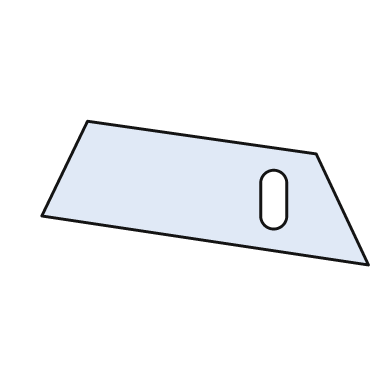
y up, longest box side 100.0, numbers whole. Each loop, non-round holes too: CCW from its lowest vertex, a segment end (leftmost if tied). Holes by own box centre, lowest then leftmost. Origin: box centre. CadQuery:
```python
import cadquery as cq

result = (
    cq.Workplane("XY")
    .moveTo(50.0, -22.0)
    .lineTo(34.0, 12.0)
    .lineTo(-36.0, 22.0)
    .lineTo(-50.0, -7.0)
    .close()
    .moveTo(17.0, -7.0)
    .threePointArc((21.0, -11.0), (25.0, -7.0))
    .lineTo(25.0, 3.0)
    .threePointArc((21.0, 7.0), (17.0, 3.0))
    .close()
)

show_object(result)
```